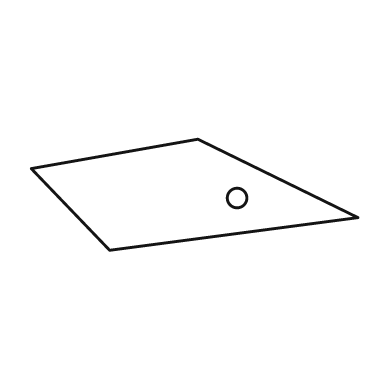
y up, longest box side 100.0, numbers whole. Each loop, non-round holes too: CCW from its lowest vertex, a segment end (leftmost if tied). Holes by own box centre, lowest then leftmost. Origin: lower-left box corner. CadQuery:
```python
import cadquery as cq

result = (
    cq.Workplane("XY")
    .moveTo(24.0, 0.0)
    .lineTo(100.0, 10.0)
    .lineTo(51.0, 34.0)
    .lineTo(0.0, 25.0)
    .close()
    .moveTo(63.0, 16.0)
    .circle(3.0)
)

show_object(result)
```